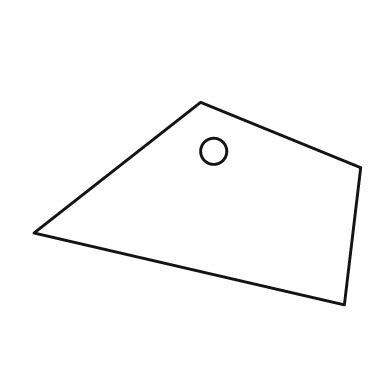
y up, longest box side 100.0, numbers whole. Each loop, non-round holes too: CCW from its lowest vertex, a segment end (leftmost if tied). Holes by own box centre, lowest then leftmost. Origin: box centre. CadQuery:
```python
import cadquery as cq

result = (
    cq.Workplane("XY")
    .moveTo(45.0, -31.0)
    .lineTo(50.0, 11.0)
    .lineTo(1.0, 31.0)
    .lineTo(-50.0, -9.0)
    .close()
    .moveTo(5.0, 16.0)
    .circle(4.0)
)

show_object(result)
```